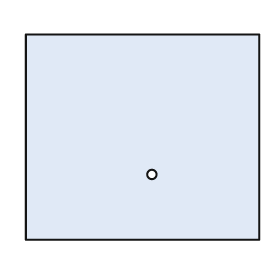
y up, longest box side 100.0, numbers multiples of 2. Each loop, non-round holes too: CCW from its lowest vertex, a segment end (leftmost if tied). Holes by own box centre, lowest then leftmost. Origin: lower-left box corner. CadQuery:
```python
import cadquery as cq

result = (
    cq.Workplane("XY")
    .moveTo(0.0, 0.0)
    .lineTo(100.0, 0.0)
    .lineTo(100.0, 88.0)
    .lineTo(0.0, 88.0)
    .close()
    .moveTo(54.0, 28.0)
    .circle(2.0)
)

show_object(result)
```